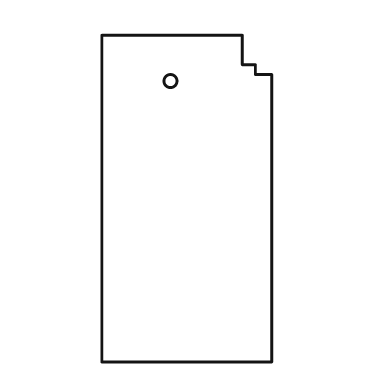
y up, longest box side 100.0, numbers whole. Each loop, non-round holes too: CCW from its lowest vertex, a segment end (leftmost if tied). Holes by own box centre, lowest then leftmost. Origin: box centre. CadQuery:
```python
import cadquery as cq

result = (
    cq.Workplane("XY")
    .moveTo(-26.0, -50.0)
    .lineTo(26.0, -50.0)
    .lineTo(26.0, 38.0)
    .lineTo(21.0, 38.0)
    .lineTo(21.0, 41.0)
    .lineTo(17.0, 41.0)
    .lineTo(17.0, 50.0)
    .lineTo(-26.0, 50.0)
    .close()
    .moveTo(-5.0, 36.0)
    .circle(2.0)
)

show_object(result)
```